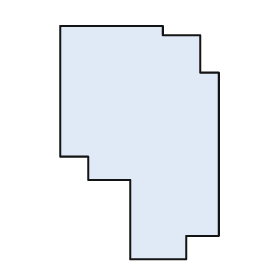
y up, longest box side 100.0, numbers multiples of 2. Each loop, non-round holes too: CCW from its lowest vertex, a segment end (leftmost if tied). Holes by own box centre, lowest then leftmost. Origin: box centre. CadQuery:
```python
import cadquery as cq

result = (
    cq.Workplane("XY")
    .moveTo(-4.0, -50.0)
    .lineTo(20.0, -50.0)
    .lineTo(20.0, -40.0)
    .lineTo(34.0, -40.0)
    .lineTo(34.0, 30.0)
    .lineTo(26.0, 30.0)
    .lineTo(26.0, 46.0)
    .lineTo(10.0, 46.0)
    .lineTo(10.0, 50.0)
    .lineTo(-34.0, 50.0)
    .lineTo(-34.0, -6.0)
    .lineTo(-22.0, -6.0)
    .lineTo(-22.0, -16.0)
    .lineTo(-4.0, -16.0)
    .close()
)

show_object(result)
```